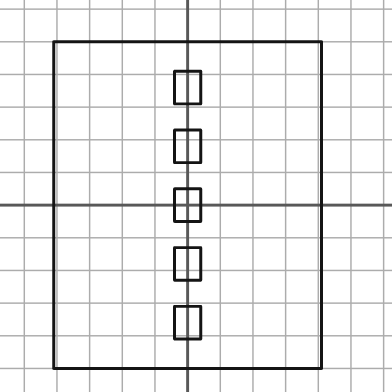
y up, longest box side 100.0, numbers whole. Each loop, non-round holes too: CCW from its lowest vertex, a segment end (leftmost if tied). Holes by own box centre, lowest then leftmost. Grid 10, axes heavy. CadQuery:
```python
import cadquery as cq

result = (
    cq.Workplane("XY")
    .moveTo(-41.0, -50.0)
    .lineTo(41.0, -50.0)
    .lineTo(41.0, 50.0)
    .lineTo(-41.0, 50.0)
    .close()
    .moveTo(-4.0, -41.0)
    .lineTo(4.0, -41.0)
    .lineTo(4.0, -31.0)
    .lineTo(-4.0, -31.0)
    .close()
    .moveTo(-4.0, -23.0)
    .lineTo(4.0, -23.0)
    .lineTo(4.0, -13.0)
    .lineTo(-4.0, -13.0)
    .close()
    .moveTo(-4.0, -5.0)
    .lineTo(4.0, -5.0)
    .lineTo(4.0, 5.0)
    .lineTo(-4.0, 5.0)
    .close()
    .moveTo(-4.0, 13.0)
    .lineTo(4.0, 13.0)
    .lineTo(4.0, 23.0)
    .lineTo(-4.0, 23.0)
    .close()
    .moveTo(-4.0, 31.0)
    .lineTo(4.0, 31.0)
    .lineTo(4.0, 41.0)
    .lineTo(-4.0, 41.0)
    .close()
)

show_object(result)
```